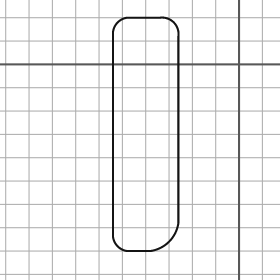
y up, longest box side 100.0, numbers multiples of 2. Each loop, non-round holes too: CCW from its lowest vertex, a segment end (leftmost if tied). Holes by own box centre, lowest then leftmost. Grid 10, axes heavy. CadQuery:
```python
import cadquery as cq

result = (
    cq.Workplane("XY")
    .moveTo(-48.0, -80.0)
    .lineTo(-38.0, -80.0)
    .threePointArc((-30.0, -76.0), (-26.0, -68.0))
    .lineTo(-26.0, 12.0)
    .threePointArc((-28.0, 18.0), (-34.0, 20.0))
    .lineTo(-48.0, 20.0)
    .threePointArc((-52.0, 18.0), (-54.0, 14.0))
    .lineTo(-54.0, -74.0)
    .threePointArc((-52.0, -78.0), (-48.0, -80.0))
    .close()
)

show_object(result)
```